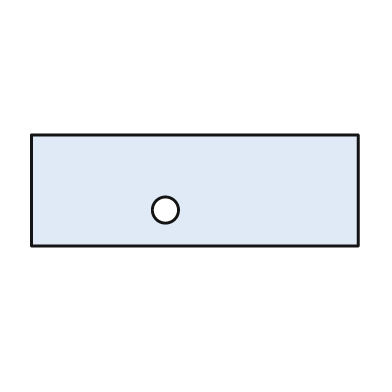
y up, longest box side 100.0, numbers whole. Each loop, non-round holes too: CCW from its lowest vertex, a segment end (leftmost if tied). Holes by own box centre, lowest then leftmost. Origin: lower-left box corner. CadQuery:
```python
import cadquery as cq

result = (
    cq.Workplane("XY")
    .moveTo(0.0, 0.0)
    .lineTo(100.0, 0.0)
    .lineTo(100.0, 34.0)
    .lineTo(0.0, 34.0)
    .close()
    .moveTo(41.0, 11.0)
    .circle(4.0)
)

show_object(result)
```